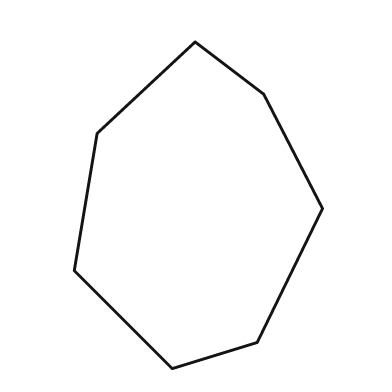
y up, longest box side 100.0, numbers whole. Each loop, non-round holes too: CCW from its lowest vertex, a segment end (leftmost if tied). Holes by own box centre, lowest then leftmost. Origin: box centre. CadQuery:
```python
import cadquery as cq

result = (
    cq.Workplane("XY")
    .moveTo(-8.0, -50.0)
    .lineTo(18.0, -42.0)
    .lineTo(38.0, -1.0)
    .lineTo(20.0, 34.0)
    .lineTo(-1.0, 50.0)
    .lineTo(-31.0, 22.0)
    .lineTo(-38.0, -20.0)
    .close()
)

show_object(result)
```